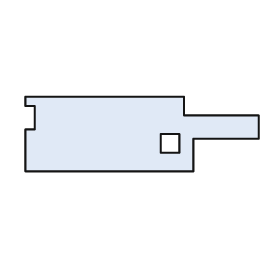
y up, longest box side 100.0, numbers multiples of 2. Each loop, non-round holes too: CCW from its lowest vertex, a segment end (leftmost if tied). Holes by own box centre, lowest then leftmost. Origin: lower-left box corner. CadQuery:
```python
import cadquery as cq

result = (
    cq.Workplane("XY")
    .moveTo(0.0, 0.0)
    .lineTo(72.0, 0.0)
    .lineTo(72.0, 14.0)
    .lineTo(100.0, 14.0)
    .lineTo(100.0, 24.0)
    .lineTo(68.0, 24.0)
    .lineTo(68.0, 32.0)
    .lineTo(0.0, 32.0)
    .lineTo(0.0, 28.0)
    .lineTo(4.0, 28.0)
    .lineTo(4.0, 18.0)
    .lineTo(0.0, 18.0)
    .close()
    .moveTo(58.0, 8.0)
    .lineTo(66.0, 8.0)
    .lineTo(66.0, 16.0)
    .lineTo(58.0, 16.0)
    .close()
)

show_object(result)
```